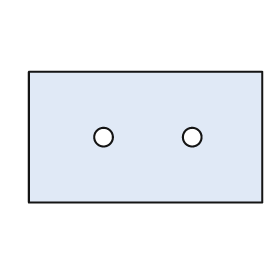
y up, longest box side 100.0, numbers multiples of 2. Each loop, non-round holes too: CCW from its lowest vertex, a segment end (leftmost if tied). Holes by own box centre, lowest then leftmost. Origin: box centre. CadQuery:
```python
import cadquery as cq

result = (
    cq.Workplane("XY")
    .moveTo(-50.0, -28.0)
    .lineTo(50.0, -28.0)
    .lineTo(50.0, 28.0)
    .lineTo(-50.0, 28.0)
    .close()
    .moveTo(-18.0, 0.0)
    .circle(4.0)
    .moveTo(20.0, 0.0)
    .circle(4.0)
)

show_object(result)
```